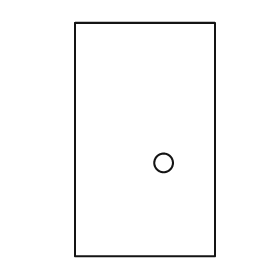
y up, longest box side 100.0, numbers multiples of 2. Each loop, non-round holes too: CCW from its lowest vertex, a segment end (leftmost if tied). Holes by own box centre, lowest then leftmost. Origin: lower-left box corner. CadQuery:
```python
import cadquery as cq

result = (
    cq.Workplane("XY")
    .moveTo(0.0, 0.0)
    .lineTo(60.0, 0.0)
    .lineTo(60.0, 100.0)
    .lineTo(0.0, 100.0)
    .close()
    .moveTo(38.0, 40.0)
    .circle(4.0)
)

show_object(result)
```